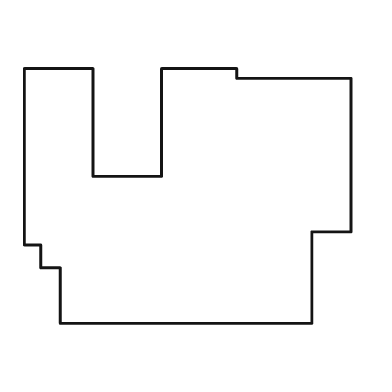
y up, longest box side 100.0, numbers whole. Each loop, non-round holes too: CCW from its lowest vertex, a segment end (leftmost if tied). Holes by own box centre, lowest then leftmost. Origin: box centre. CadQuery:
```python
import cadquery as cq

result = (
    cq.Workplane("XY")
    .moveTo(-39.0, -39.0)
    .lineTo(38.0, -39.0)
    .lineTo(38.0, -11.0)
    .lineTo(50.0, -11.0)
    .lineTo(50.0, 36.0)
    .lineTo(15.0, 36.0)
    .lineTo(15.0, 39.0)
    .lineTo(-8.0, 39.0)
    .lineTo(-8.0, 6.0)
    .lineTo(-29.0, 6.0)
    .lineTo(-29.0, 39.0)
    .lineTo(-50.0, 39.0)
    .lineTo(-50.0, -15.0)
    .lineTo(-45.0, -15.0)
    .lineTo(-45.0, -22.0)
    .lineTo(-39.0, -22.0)
    .close()
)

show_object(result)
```